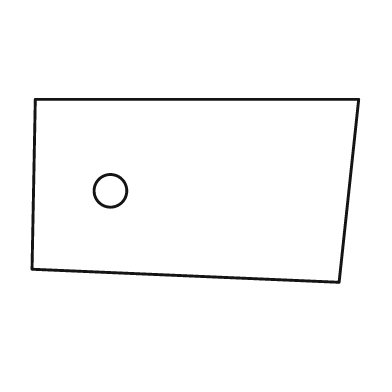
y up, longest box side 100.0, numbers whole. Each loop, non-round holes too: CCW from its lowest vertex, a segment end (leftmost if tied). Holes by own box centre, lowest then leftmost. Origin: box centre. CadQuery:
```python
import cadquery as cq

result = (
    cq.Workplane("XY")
    .moveTo(44.0, -28.0)
    .lineTo(50.0, 28.0)
    .lineTo(-49.0, 28.0)
    .lineTo(-50.0, -24.0)
    .close()
    .moveTo(-26.0, 0.0)
    .circle(5.0)
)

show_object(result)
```